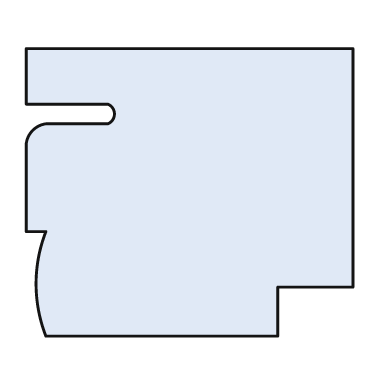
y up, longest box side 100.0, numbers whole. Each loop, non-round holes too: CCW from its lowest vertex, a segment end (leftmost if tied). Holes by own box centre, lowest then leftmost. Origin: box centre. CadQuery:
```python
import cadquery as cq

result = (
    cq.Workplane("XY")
    .moveTo(-44.0, -44.0)
    .lineTo(27.0, -44.0)
    .lineTo(27.0, -29.0)
    .lineTo(50.0, -29.0)
    .lineTo(50.0, 44.0)
    .lineTo(-50.0, 44.0)
    .lineTo(-50.0, 27.0)
    .lineTo(-25.0, 27.0)
    .threePointArc((-23.0, 24.0), (-25.0, 21.0))
    .lineTo(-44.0, 21.0)
    .threePointArc((-48.0, 19.0), (-50.0, 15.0))
    .lineTo(-50.0, -12.0)
    .lineTo(-44.0, -12.0)
    .threePointArc((-47.0, -28.0), (-44.0, -44.0))
    .close()
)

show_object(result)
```